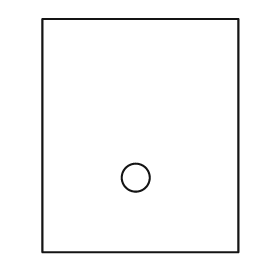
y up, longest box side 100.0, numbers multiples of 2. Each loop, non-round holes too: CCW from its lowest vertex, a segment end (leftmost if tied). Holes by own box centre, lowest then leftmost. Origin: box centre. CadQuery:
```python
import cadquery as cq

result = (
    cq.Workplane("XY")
    .moveTo(-42.0, -50.0)
    .lineTo(42.0, -50.0)
    .lineTo(42.0, 50.0)
    .lineTo(-42.0, 50.0)
    .close()
    .moveTo(-2.0, -18.0)
    .circle(6.0)
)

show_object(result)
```